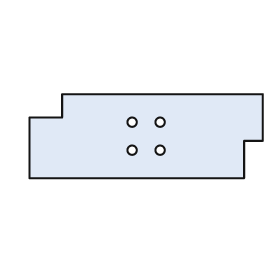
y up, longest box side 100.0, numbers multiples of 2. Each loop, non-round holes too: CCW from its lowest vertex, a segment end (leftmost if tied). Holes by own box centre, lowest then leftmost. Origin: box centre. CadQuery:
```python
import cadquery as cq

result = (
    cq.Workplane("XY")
    .moveTo(-50.0, -18.0)
    .lineTo(42.0, -18.0)
    .lineTo(42.0, -2.0)
    .lineTo(50.0, -2.0)
    .lineTo(50.0, 18.0)
    .lineTo(-36.0, 18.0)
    .lineTo(-36.0, 8.0)
    .lineTo(-50.0, 8.0)
    .close()
    .moveTo(-6.0, -6.0)
    .circle(2.0)
    .moveTo(6.0, -6.0)
    .circle(2.0)
    .moveTo(-6.0, 6.0)
    .circle(2.0)
    .moveTo(6.0, 6.0)
    .circle(2.0)
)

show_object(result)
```